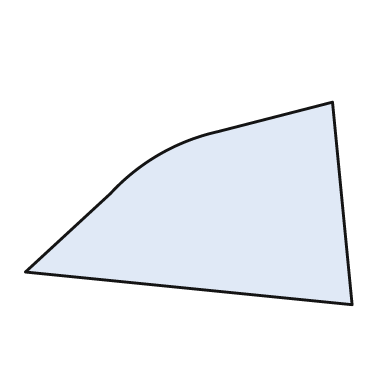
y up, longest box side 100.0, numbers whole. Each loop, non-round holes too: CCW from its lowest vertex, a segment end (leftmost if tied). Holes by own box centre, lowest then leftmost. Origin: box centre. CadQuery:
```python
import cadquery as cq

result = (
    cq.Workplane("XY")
    .moveTo(50.0, -31.0)
    .lineTo(44.0, 31.0)
    .lineTo(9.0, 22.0)
    .threePointArc((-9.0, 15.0), (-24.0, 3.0))
    .lineTo(-50.0, -21.0)
    .close()
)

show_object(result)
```